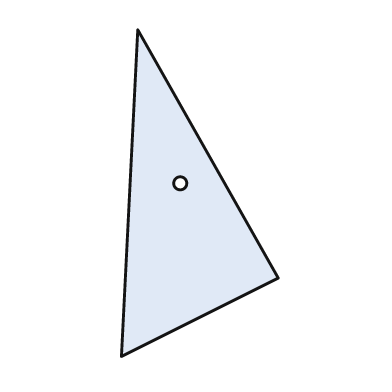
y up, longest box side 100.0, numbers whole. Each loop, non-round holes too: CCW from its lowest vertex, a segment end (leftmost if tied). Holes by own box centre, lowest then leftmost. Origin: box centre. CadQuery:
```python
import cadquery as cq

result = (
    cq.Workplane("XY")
    .moveTo(-24.0, -50.0)
    .lineTo(24.0, -26.0)
    .lineTo(-19.0, 50.0)
    .close()
    .moveTo(-6.0, 3.0)
    .circle(2.0)
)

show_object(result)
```